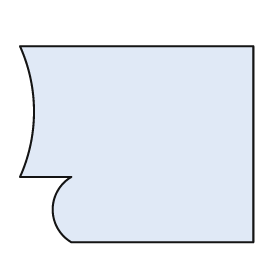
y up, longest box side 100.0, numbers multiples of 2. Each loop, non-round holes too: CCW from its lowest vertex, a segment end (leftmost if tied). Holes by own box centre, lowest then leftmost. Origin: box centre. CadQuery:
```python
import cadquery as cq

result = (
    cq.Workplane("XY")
    .moveTo(-28.0, -42.0)
    .lineTo(50.0, -42.0)
    .lineTo(50.0, 42.0)
    .lineTo(-50.0, 42.0)
    .threePointArc((-44.0, 14.0), (-50.0, -14.0))
    .lineTo(-28.0, -14.0)
    .threePointArc((-36.0, -28.0), (-28.0, -42.0))
    .close()
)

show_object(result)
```